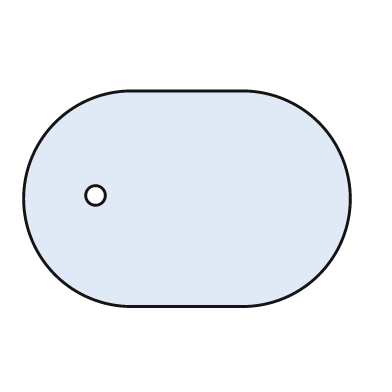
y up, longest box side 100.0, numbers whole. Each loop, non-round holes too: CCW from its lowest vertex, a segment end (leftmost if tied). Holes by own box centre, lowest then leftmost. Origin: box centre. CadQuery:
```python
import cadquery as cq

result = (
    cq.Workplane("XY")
    .moveTo(-17.0, -33.0)
    .lineTo(17.0, -33.0)
    .threePointArc((50.0, 0.0), (17.0, 33.0))
    .lineTo(-17.0, 33.0)
    .threePointArc((-50.0, 0.0), (-17.0, -33.0))
    .close()
    .moveTo(-28.0, 1.0)
    .circle(3.0)
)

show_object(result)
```